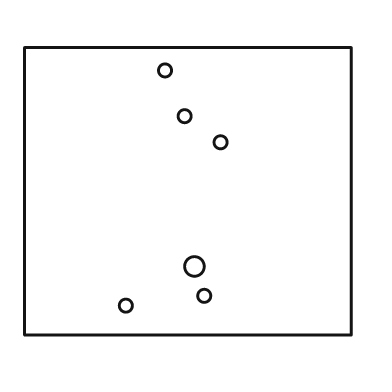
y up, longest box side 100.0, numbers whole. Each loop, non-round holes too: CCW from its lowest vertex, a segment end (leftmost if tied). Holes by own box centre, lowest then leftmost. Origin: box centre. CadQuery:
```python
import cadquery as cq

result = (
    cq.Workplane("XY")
    .moveTo(-50.0, -44.0)
    .lineTo(50.0, -44.0)
    .lineTo(50.0, 44.0)
    .lineTo(-50.0, 44.0)
    .close()
    .moveTo(-19.0, -35.0)
    .circle(2.0)
    .moveTo(5.0, -32.0)
    .circle(2.0)
    .moveTo(2.0, -23.0)
    .circle(3.0)
    .moveTo(10.0, 15.0)
    .circle(2.0)
    .moveTo(-1.0, 23.0)
    .circle(2.0)
    .moveTo(-7.0, 37.0)
    .circle(2.0)
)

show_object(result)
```